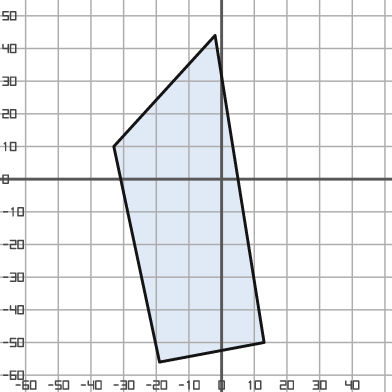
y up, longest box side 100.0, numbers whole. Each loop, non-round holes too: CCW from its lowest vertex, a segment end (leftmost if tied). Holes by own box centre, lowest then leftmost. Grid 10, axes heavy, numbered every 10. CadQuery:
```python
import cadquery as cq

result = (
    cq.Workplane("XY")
    .moveTo(-19.0, -56.0)
    .lineTo(13.0, -50.0)
    .lineTo(-2.0, 44.0)
    .lineTo(-33.0, 10.0)
    .close()
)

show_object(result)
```